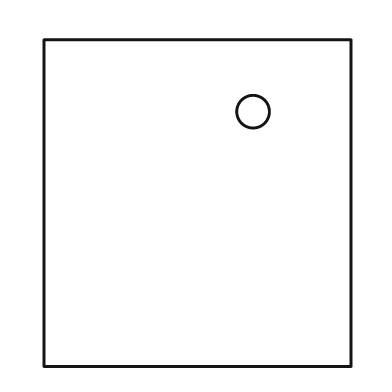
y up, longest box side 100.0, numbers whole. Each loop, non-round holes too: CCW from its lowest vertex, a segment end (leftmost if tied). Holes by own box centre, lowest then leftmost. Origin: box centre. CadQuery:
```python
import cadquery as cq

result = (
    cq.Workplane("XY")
    .moveTo(-47.0, -50.0)
    .lineTo(47.0, -50.0)
    .lineTo(47.0, 50.0)
    .lineTo(-47.0, 50.0)
    .close()
    .moveTo(17.0, 28.0)
    .circle(5.0)
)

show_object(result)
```